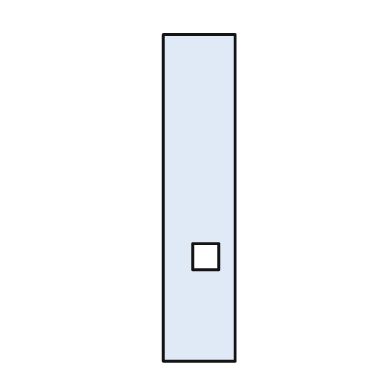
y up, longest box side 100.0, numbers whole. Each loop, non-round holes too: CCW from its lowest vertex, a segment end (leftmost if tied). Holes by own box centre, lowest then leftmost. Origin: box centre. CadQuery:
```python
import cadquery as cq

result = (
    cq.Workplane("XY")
    .moveTo(-11.0, -50.0)
    .lineTo(11.0, -50.0)
    .lineTo(11.0, 50.0)
    .lineTo(-11.0, 50.0)
    .close()
    .moveTo(-2.0, -22.0)
    .lineTo(6.0, -22.0)
    .lineTo(6.0, -14.0)
    .lineTo(-2.0, -14.0)
    .close()
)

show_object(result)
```